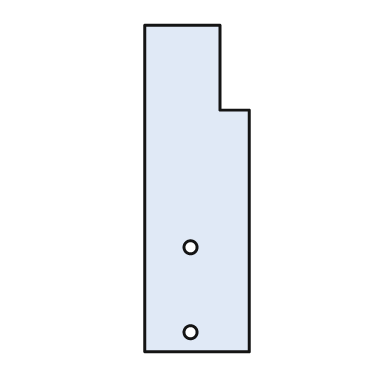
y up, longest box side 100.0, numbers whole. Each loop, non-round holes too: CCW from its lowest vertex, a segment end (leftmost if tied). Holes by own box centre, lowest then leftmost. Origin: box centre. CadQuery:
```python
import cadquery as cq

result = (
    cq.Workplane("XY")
    .moveTo(-16.0, -50.0)
    .lineTo(16.0, -50.0)
    .lineTo(16.0, 24.0)
    .lineTo(7.0, 24.0)
    .lineTo(7.0, 50.0)
    .lineTo(-16.0, 50.0)
    .close()
    .moveTo(-2.0, -44.0)
    .circle(2.0)
    .moveTo(-2.0, -18.0)
    .circle(2.0)
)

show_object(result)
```